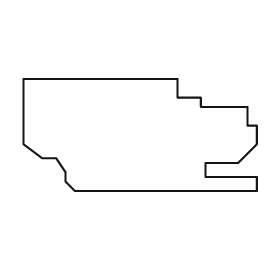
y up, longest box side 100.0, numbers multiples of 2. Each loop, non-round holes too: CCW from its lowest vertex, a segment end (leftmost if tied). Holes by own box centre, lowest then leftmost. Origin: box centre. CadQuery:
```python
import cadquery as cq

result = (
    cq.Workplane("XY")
    .moveTo(-28.0, -24.0)
    .lineTo(50.0, -24.0)
    .lineTo(50.0, -18.0)
    .lineTo(28.0, -18.0)
    .lineTo(28.0, -12.0)
    .lineTo(42.0, -12.0)
    .lineTo(50.0, -4.0)
    .lineTo(50.0, 4.0)
    .lineTo(46.0, 4.0)
    .lineTo(46.0, 12.0)
    .lineTo(26.0, 12.0)
    .lineTo(26.0, 16.0)
    .lineTo(16.0, 16.0)
    .lineTo(16.0, 24.0)
    .lineTo(-50.0, 24.0)
    .lineTo(-50.0, -4.0)
    .lineTo(-42.0, -10.0)
    .lineTo(-36.0, -10.0)
    .lineTo(-32.0, -16.0)
    .lineTo(-32.0, -20.0)
    .close()
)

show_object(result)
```